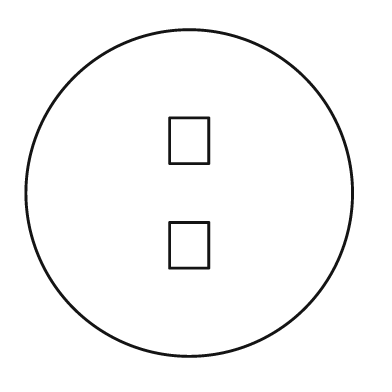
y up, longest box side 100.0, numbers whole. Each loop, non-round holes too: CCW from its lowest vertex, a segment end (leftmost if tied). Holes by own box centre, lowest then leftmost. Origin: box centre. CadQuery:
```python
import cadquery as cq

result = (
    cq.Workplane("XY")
    .moveTo(0.0, 0.0)
    .circle(50.0)
    .moveTo(-6.0, -23.0)
    .lineTo(6.0, -23.0)
    .lineTo(6.0, -9.0)
    .lineTo(-6.0, -9.0)
    .close()
    .moveTo(-6.0, 9.0)
    .lineTo(6.0, 9.0)
    .lineTo(6.0, 23.0)
    .lineTo(-6.0, 23.0)
    .close()
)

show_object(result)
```